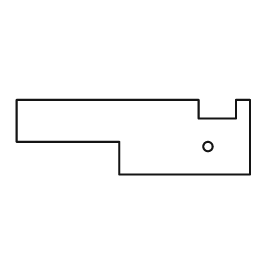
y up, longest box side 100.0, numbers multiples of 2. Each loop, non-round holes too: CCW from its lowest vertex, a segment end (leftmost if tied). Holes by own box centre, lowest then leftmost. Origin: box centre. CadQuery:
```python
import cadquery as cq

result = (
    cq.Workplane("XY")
    .moveTo(-6.0, -16.0)
    .lineTo(50.0, -16.0)
    .lineTo(50.0, 16.0)
    .lineTo(44.0, 16.0)
    .lineTo(44.0, 8.0)
    .lineTo(28.0, 8.0)
    .lineTo(28.0, 16.0)
    .lineTo(-50.0, 16.0)
    .lineTo(-50.0, -2.0)
    .lineTo(-6.0, -2.0)
    .close()
    .moveTo(32.0, -4.0)
    .circle(2.0)
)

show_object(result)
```